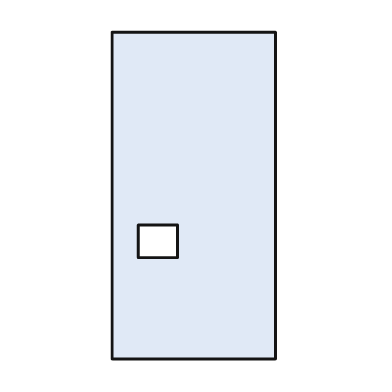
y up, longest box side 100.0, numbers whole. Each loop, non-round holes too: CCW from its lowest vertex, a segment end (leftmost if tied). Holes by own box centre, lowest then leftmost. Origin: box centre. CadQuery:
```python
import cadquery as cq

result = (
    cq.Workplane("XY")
    .moveTo(-25.0, -50.0)
    .lineTo(25.0, -50.0)
    .lineTo(25.0, 50.0)
    .lineTo(-25.0, 50.0)
    .close()
    .moveTo(-17.0, -19.0)
    .lineTo(-5.0, -19.0)
    .lineTo(-5.0, -9.0)
    .lineTo(-17.0, -9.0)
    .close()
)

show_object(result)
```